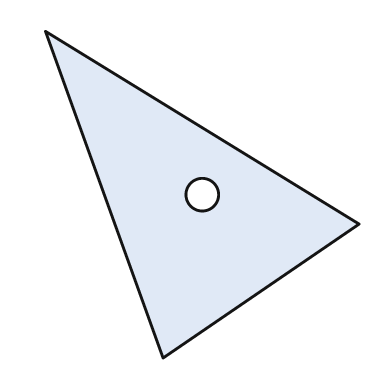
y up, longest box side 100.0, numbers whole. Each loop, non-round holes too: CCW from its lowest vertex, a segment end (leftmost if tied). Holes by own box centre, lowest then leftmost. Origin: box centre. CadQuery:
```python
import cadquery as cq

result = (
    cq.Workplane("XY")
    .moveTo(-12.0, -50.0)
    .lineTo(48.0, -9.0)
    .lineTo(-48.0, 50.0)
    .close()
    .moveTo(0.0, 0.0)
    .circle(5.0)
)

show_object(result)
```